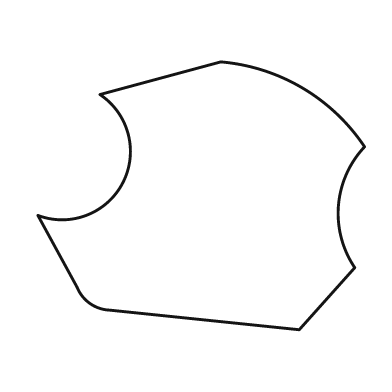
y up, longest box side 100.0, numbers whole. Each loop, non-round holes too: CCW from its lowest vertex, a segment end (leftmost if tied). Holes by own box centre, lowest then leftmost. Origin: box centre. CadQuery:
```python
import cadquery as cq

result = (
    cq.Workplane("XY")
    .moveTo(30.0, -41.0)
    .lineTo(47.0, -22.0)
    .threePointArc((42.0, -3.0), (50.0, 15.0))
    .threePointArc((31.0, 33.0), (6.0, 41.0))
    .lineTo(-31.0, 31.0)
    .threePointArc((-24.0, 4.0), (-50.0, -6.0))
    .lineTo(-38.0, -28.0)
    .threePointArc((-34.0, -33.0), (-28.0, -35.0))
    .close()
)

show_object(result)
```